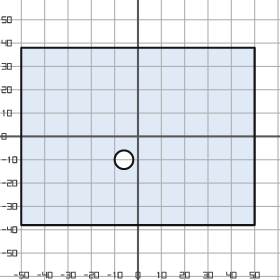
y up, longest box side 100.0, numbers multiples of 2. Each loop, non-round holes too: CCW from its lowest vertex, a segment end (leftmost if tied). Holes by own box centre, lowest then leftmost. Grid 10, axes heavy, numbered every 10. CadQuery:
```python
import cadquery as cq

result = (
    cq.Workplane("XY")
    .moveTo(-50.0, -38.0)
    .lineTo(50.0, -38.0)
    .lineTo(50.0, 38.0)
    .lineTo(-50.0, 38.0)
    .close()
    .moveTo(-6.0, -10.0)
    .circle(4.0)
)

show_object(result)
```